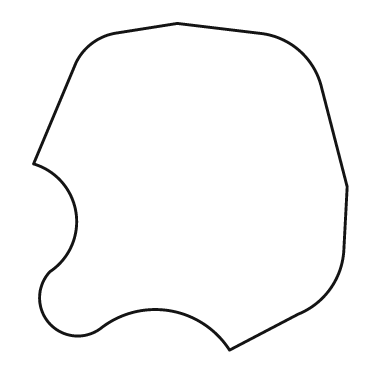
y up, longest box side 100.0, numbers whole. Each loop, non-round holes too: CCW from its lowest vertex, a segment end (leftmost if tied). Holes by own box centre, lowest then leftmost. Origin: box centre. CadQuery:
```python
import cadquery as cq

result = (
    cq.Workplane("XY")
    .moveTo(12.0, -50.0)
    .lineTo(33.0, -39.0)
    .threePointArc((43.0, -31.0), (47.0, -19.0))
    .lineTo(48.0, 0.0)
    .lineTo(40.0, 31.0)
    .threePointArc((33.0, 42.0), (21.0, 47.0))
    .lineTo(-4.0, 50.0)
    .lineTo(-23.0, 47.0)
    .threePointArc((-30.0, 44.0), (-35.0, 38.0))
    .lineTo(-48.0, 7.0)
    .threePointArc((-35.0, -8.0), (-43.0, -26.0))
    .threePointArc((-43.0, -42.0), (-27.0, -43.0))
    .threePointArc((-6.0, -38.0), (12.0, -50.0))
    .close()
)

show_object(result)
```